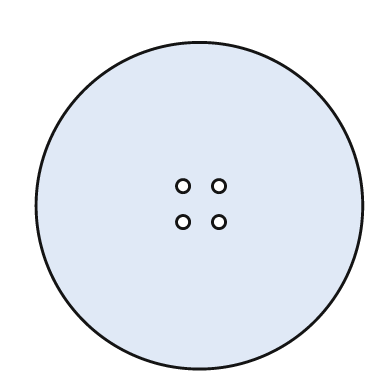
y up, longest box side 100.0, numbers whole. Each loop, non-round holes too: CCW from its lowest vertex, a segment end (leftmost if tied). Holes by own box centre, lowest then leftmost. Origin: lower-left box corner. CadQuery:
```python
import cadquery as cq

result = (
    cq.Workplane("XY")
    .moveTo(50.0, 50.0)
    .circle(50.0)
    .moveTo(45.0, 45.0)
    .circle(2.0)
    .moveTo(56.0, 45.0)
    .circle(2.0)
    .moveTo(45.0, 56.0)
    .circle(2.0)
    .moveTo(56.0, 56.0)
    .circle(2.0)
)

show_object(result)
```